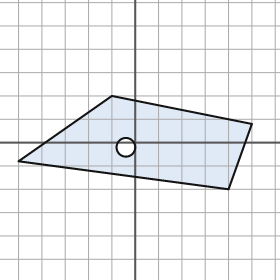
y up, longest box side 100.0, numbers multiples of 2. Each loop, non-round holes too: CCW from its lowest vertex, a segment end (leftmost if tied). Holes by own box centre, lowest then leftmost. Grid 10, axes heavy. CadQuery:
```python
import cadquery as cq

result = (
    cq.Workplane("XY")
    .moveTo(40.0, -20.0)
    .lineTo(50.0, 8.0)
    .lineTo(-10.0, 20.0)
    .lineTo(-50.0, -8.0)
    .close()
    .moveTo(-4.0, -2.0)
    .circle(4.0)
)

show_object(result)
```